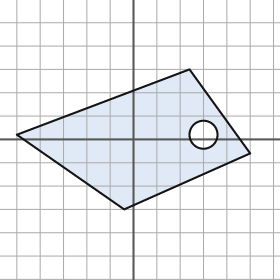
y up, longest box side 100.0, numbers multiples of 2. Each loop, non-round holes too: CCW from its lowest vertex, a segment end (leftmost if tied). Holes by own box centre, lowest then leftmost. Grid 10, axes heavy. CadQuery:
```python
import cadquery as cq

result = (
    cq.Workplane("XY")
    .moveTo(-4.0, -30.0)
    .lineTo(50.0, -6.0)
    .lineTo(24.0, 30.0)
    .lineTo(-50.0, 2.0)
    .close()
    .moveTo(30.0, 2.0)
    .circle(6.0)
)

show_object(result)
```